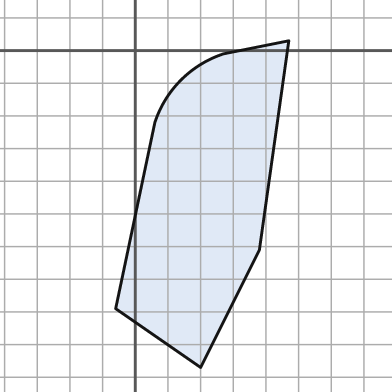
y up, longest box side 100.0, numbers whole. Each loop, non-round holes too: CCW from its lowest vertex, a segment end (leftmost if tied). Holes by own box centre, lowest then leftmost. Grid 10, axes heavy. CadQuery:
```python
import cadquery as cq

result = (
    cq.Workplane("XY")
    .moveTo(20.0, -97.0)
    .lineTo(38.0, -61.0)
    .lineTo(47.0, 3.0)
    .lineTo(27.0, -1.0)
    .threePointArc((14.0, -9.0), (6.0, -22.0))
    .lineTo(-6.0, -79.0)
    .close()
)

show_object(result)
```